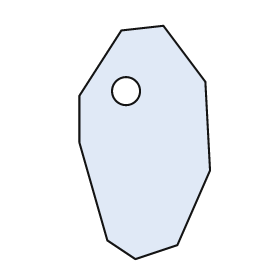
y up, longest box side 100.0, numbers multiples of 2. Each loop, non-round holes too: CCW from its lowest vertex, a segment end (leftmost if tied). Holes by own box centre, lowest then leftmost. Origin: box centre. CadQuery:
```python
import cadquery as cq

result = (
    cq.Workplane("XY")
    .moveTo(-4.0, -50.0)
    .lineTo(14.0, -44.0)
    .lineTo(28.0, -12.0)
    .lineTo(26.0, 26.0)
    .lineTo(8.0, 50.0)
    .lineTo(-10.0, 48.0)
    .lineTo(-28.0, 20.0)
    .lineTo(-28.0, 0.0)
    .lineTo(-16.0, -42.0)
    .close()
    .moveTo(-8.0, 22.0)
    .circle(6.0)
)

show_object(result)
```